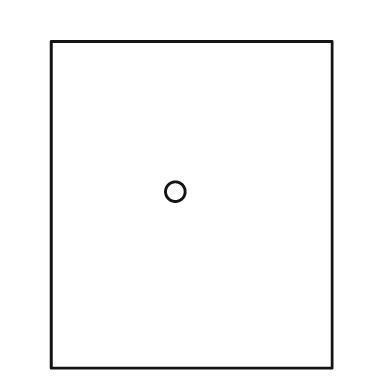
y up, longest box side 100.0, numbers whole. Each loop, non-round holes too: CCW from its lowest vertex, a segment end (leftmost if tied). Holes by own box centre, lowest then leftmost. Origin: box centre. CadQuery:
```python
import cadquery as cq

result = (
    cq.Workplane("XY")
    .moveTo(-43.0, -50.0)
    .lineTo(43.0, -50.0)
    .lineTo(43.0, 50.0)
    .lineTo(-43.0, 50.0)
    .close()
    .moveTo(-5.0, 4.0)
    .circle(3.0)
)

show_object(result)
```